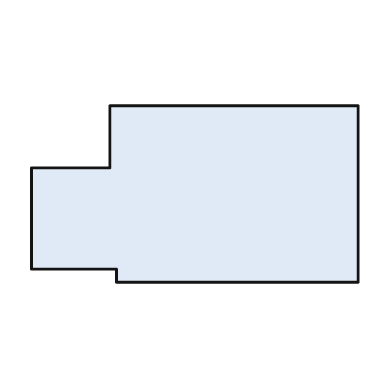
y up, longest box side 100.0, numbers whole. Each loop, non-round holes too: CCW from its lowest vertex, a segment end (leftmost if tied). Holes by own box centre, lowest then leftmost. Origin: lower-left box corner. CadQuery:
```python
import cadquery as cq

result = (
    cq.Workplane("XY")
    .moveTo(26.0, 0.0)
    .lineTo(100.0, 0.0)
    .lineTo(100.0, 54.0)
    .lineTo(24.0, 54.0)
    .lineTo(24.0, 35.0)
    .lineTo(0.0, 35.0)
    .lineTo(0.0, 4.0)
    .lineTo(26.0, 4.0)
    .close()
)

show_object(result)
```